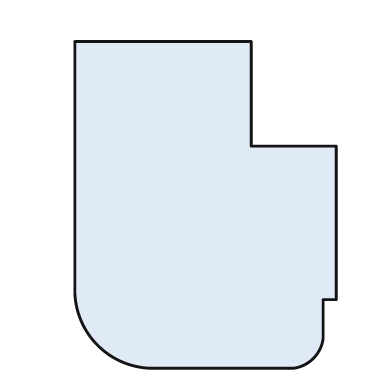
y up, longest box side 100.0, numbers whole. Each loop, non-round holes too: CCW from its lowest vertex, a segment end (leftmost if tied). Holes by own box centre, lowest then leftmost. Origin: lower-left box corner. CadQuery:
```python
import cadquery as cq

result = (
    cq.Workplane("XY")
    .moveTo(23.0, 0.0)
    .lineTo(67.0, 0.0)
    .threePointArc((73.0, 3.0), (76.0, 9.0))
    .lineTo(76.0, 21.0)
    .lineTo(80.0, 21.0)
    .lineTo(80.0, 68.0)
    .lineTo(54.0, 68.0)
    .lineTo(54.0, 100.0)
    .lineTo(0.0, 100.0)
    .lineTo(0.0, 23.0)
    .threePointArc((7.0, 7.0), (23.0, 0.0))
    .close()
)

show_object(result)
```